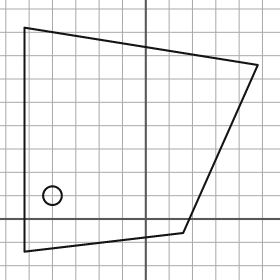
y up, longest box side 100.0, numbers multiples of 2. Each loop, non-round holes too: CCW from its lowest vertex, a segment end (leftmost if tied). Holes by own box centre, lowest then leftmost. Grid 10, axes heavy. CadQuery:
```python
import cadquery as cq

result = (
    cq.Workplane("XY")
    .moveTo(-52.0, -14.0)
    .lineTo(16.0, -6.0)
    .lineTo(48.0, 66.0)
    .lineTo(-52.0, 82.0)
    .close()
    .moveTo(-40.0, 10.0)
    .circle(4.0)
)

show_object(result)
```